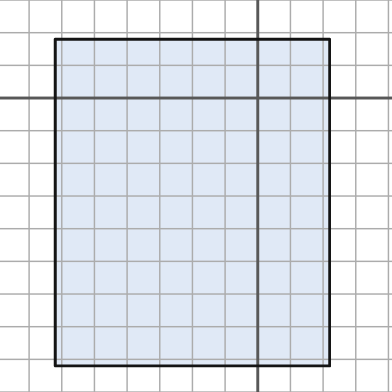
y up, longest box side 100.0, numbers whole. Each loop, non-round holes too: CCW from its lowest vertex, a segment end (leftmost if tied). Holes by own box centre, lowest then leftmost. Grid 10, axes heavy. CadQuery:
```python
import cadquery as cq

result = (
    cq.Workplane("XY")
    .moveTo(-62.0, -82.0)
    .lineTo(22.0, -82.0)
    .lineTo(22.0, 18.0)
    .lineTo(-62.0, 18.0)
    .close()
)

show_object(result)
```